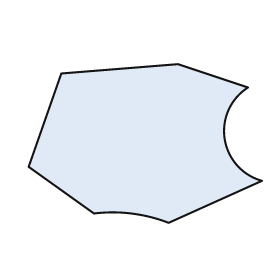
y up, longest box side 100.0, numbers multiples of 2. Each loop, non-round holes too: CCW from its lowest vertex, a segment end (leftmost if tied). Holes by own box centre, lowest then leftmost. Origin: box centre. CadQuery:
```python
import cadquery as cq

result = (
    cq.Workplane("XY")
    .moveTo(10.0, -34.0)
    .lineTo(50.0, -16.0)
    .threePointArc((34.0, 2.0), (44.0, 24.0))
    .lineTo(14.0, 34.0)
    .lineTo(-36.0, 30.0)
    .lineTo(-50.0, -10.0)
    .lineTo(-22.0, -30.0)
    .threePointArc((-6.0, -30.0), (10.0, -34.0))
    .close()
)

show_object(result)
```